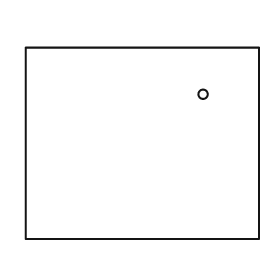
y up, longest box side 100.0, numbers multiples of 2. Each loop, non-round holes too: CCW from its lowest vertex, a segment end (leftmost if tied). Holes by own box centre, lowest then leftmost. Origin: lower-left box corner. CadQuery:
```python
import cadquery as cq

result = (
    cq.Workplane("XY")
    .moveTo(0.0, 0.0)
    .lineTo(100.0, 0.0)
    .lineTo(100.0, 82.0)
    .lineTo(0.0, 82.0)
    .close()
    .moveTo(76.0, 62.0)
    .circle(2.0)
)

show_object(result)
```